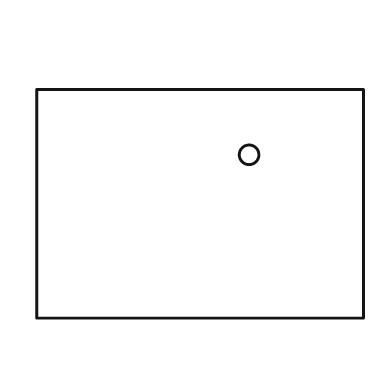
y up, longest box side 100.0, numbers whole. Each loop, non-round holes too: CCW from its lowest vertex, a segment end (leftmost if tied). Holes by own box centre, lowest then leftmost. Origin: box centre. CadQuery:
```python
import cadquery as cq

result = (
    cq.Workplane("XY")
    .moveTo(-50.0, -35.0)
    .lineTo(50.0, -35.0)
    .lineTo(50.0, 35.0)
    .lineTo(-50.0, 35.0)
    .close()
    .moveTo(15.0, 15.0)
    .circle(3.0)
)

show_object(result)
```